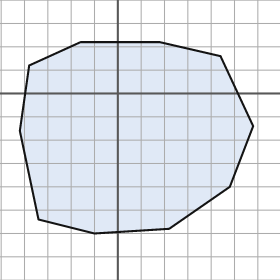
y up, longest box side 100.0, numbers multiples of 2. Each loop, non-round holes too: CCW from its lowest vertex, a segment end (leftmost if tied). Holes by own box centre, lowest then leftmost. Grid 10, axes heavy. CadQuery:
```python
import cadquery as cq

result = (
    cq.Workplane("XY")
    .moveTo(-10.0, -60.0)
    .lineTo(22.0, -58.0)
    .lineTo(48.0, -40.0)
    .lineTo(58.0, -14.0)
    .lineTo(44.0, 16.0)
    .lineTo(18.0, 22.0)
    .lineTo(-16.0, 22.0)
    .lineTo(-38.0, 12.0)
    .lineTo(-42.0, -16.0)
    .lineTo(-34.0, -54.0)
    .close()
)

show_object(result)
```